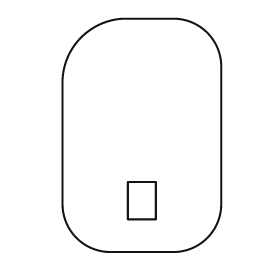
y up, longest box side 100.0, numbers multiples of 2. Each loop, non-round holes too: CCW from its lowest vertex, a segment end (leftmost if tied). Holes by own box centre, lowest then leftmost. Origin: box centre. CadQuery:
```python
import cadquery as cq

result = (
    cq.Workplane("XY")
    .moveTo(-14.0, -50.0)
    .lineTo(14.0, -50.0)
    .threePointArc((28.0, -44.0), (34.0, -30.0))
    .lineTo(34.0, 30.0)
    .threePointArc((28.0, 44.0), (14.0, 50.0))
    .lineTo(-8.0, 50.0)
    .threePointArc((-26.0, 42.0), (-34.0, 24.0))
    .lineTo(-34.0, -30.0)
    .threePointArc((-28.0, -44.0), (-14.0, -50.0))
    .close()
    .moveTo(-6.0, -36.0)
    .lineTo(6.0, -36.0)
    .lineTo(6.0, -20.0)
    .lineTo(-6.0, -20.0)
    .close()
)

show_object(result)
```